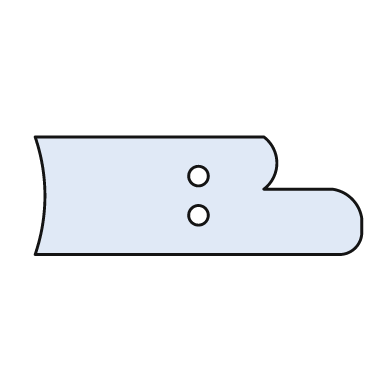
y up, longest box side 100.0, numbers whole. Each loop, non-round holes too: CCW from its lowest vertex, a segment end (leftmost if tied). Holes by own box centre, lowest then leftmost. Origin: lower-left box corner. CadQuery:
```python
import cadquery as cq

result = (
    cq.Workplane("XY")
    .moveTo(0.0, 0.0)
    .lineTo(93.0, 0.0)
    .threePointArc((98.0, 2.0), (100.0, 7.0))
    .lineTo(100.0, 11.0)
    .threePointArc((97.0, 17.0), (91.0, 20.0))
    .lineTo(70.0, 20.0)
    .threePointArc((74.0, 28.0), (70.0, 36.0))
    .lineTo(0.0, 36.0)
    .threePointArc((3.0, 18.0), (0.0, 0.0))
    .close()
    .moveTo(50.0, 12.0)
    .circle(3.0)
    .moveTo(50.0, 24.0)
    .circle(3.0)
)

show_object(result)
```